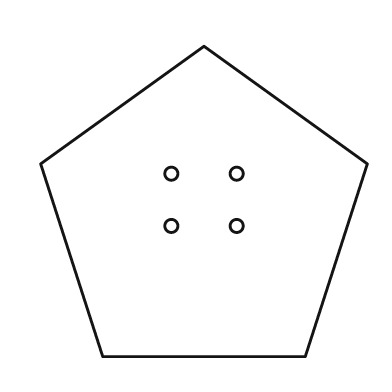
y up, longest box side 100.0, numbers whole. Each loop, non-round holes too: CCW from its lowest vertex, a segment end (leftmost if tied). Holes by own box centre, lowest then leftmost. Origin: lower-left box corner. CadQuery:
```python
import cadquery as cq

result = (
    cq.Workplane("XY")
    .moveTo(19.0, 0.0)
    .lineTo(81.0, 0.0)
    .lineTo(100.0, 59.0)
    .lineTo(50.0, 95.0)
    .lineTo(0.0, 59.0)
    .close()
    .moveTo(40.0, 40.0)
    .circle(2.0)
    .moveTo(60.0, 40.0)
    .circle(2.0)
    .moveTo(40.0, 56.0)
    .circle(2.0)
    .moveTo(60.0, 56.0)
    .circle(2.0)
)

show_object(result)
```